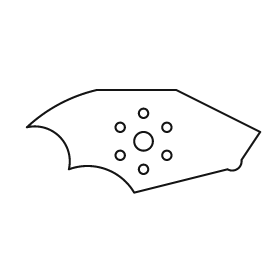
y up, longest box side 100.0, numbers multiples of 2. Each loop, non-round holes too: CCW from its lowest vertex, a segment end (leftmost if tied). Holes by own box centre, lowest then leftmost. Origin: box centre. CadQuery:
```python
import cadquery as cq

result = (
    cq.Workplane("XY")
    .moveTo(-4.0, -22.0)
    .lineTo(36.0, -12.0)
    .threePointArc((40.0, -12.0), (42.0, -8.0))
    .lineTo(50.0, 4.0)
    .lineTo(14.0, 22.0)
    .lineTo(-20.0, 22.0)
    .threePointArc((-36.0, 16.0), (-50.0, 6.0))
    .threePointArc((-36.0, 2.0), (-32.0, -12.0))
    .threePointArc((-16.0, -12.0), (-4.0, -22.0))
    .close()
    .moveTo(0.0, -12.0)
    .circle(2.0)
    .moveTo(-10.0, -6.0)
    .circle(2.0)
    .moveTo(10.0, -6.0)
    .circle(2.0)
    .moveTo(0.0, 0.0)
    .circle(4.0)
    .moveTo(-10.0, 6.0)
    .circle(2.0)
    .moveTo(10.0, 6.0)
    .circle(2.0)
    .moveTo(0.0, 12.0)
    .circle(2.0)
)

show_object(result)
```